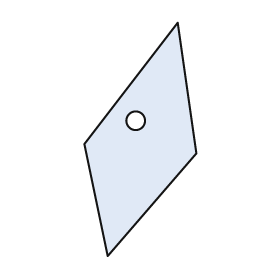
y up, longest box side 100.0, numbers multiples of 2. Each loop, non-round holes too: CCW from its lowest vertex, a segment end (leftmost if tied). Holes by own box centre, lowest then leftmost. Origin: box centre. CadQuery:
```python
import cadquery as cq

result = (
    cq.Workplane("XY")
    .moveTo(-14.0, -50.0)
    .lineTo(24.0, -6.0)
    .lineTo(16.0, 50.0)
    .lineTo(-24.0, -2.0)
    .close()
    .moveTo(-2.0, 8.0)
    .circle(4.0)
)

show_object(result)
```